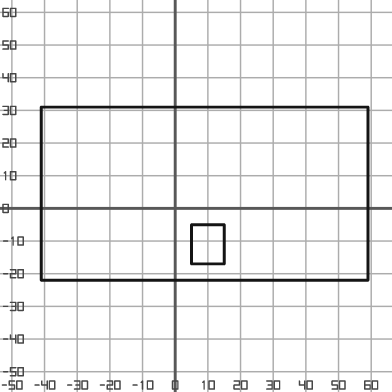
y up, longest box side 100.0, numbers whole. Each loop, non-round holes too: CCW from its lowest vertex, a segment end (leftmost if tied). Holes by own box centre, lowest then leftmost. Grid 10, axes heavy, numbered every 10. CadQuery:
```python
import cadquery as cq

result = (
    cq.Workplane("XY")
    .moveTo(-41.0, -22.0)
    .lineTo(59.0, -22.0)
    .lineTo(59.0, 31.0)
    .lineTo(-41.0, 31.0)
    .close()
    .moveTo(5.0, -17.0)
    .lineTo(15.0, -17.0)
    .lineTo(15.0, -5.0)
    .lineTo(5.0, -5.0)
    .close()
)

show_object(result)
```